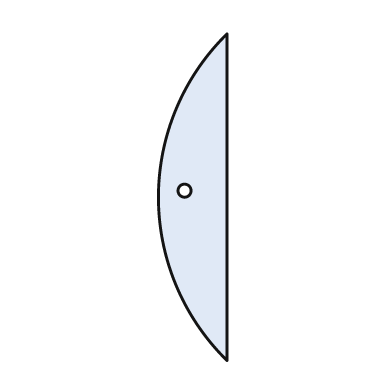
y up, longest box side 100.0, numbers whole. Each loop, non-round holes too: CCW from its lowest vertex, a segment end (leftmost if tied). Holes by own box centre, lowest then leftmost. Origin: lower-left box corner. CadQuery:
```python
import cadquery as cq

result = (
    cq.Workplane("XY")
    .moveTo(21.0, 0.0)
    .lineTo(21.0, 100.0)
    .threePointArc((0.0, 50.0), (21.0, 0.0))
    .close()
    .moveTo(8.0, 52.0)
    .circle(2.0)
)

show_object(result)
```